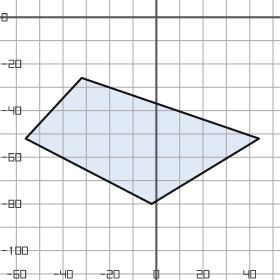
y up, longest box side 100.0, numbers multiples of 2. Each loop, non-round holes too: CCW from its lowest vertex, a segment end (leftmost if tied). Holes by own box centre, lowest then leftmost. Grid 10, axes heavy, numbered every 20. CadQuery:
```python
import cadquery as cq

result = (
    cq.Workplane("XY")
    .moveTo(-2.0, -80.0)
    .lineTo(44.0, -52.0)
    .lineTo(-32.0, -26.0)
    .lineTo(-56.0, -52.0)
    .close()
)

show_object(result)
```